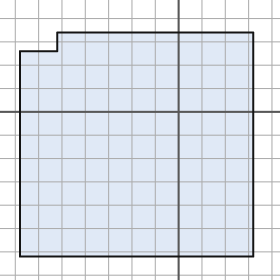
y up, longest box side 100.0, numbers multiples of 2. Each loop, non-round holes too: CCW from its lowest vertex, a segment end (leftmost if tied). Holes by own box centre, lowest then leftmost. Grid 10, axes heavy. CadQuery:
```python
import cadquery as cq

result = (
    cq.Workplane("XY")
    .moveTo(-68.0, -62.0)
    .lineTo(32.0, -62.0)
    .lineTo(32.0, 34.0)
    .lineTo(-52.0, 34.0)
    .lineTo(-52.0, 26.0)
    .lineTo(-68.0, 26.0)
    .close()
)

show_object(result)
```